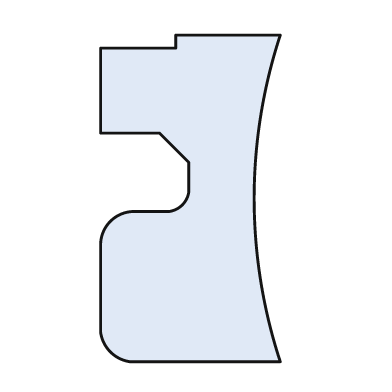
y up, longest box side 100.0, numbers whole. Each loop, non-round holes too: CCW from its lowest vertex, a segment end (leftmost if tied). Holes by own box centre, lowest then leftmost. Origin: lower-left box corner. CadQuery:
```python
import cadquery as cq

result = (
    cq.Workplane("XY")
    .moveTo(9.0, 0.0)
    .lineTo(55.0, 0.0)
    .threePointArc((47.0, 50.0), (55.0, 100.0))
    .lineTo(23.0, 100.0)
    .lineTo(23.0, 96.0)
    .lineTo(0.0, 96.0)
    .lineTo(0.0, 70.0)
    .lineTo(18.0, 70.0)
    .lineTo(27.0, 61.0)
    .lineTo(27.0, 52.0)
    .threePointArc((25.0, 48.0), (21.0, 46.0))
    .lineTo(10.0, 46.0)
    .threePointArc((3.0, 43.0), (0.0, 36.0))
    .lineTo(0.0, 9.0)
    .threePointArc((3.0, 3.0), (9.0, 0.0))
    .close()
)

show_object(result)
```